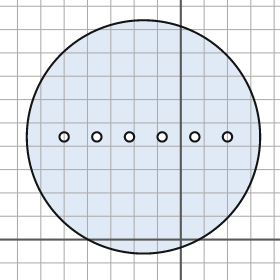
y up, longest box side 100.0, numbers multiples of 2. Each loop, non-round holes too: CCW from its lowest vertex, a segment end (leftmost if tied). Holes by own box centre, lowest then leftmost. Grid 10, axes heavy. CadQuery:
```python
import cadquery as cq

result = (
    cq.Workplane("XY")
    .moveTo(-16.0, 44.0)
    .circle(50.0)
    .moveTo(-50.0, 44.0)
    .circle(2.0)
    .moveTo(-36.0, 44.0)
    .circle(2.0)
    .moveTo(-22.0, 44.0)
    .circle(2.0)
    .moveTo(-8.0, 44.0)
    .circle(2.0)
    .moveTo(6.0, 44.0)
    .circle(2.0)
    .moveTo(20.0, 44.0)
    .circle(2.0)
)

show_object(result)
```